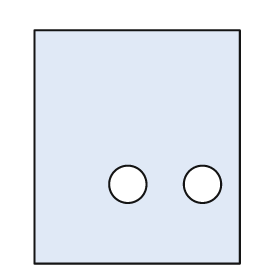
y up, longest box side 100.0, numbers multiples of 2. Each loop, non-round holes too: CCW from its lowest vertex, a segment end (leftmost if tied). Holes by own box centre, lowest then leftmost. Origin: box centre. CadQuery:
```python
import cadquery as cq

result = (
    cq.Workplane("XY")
    .moveTo(-44.0, -50.0)
    .lineTo(44.0, -50.0)
    .lineTo(44.0, 50.0)
    .lineTo(-44.0, 50.0)
    .close()
    .moveTo(-4.0, -16.0)
    .circle(8.0)
    .moveTo(28.0, -16.0)
    .circle(8.0)
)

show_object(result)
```